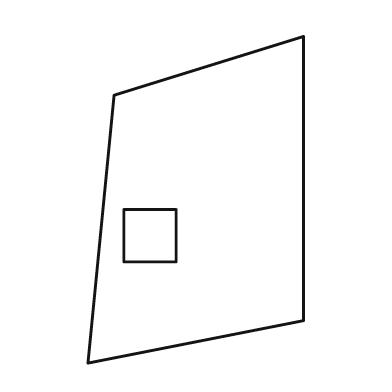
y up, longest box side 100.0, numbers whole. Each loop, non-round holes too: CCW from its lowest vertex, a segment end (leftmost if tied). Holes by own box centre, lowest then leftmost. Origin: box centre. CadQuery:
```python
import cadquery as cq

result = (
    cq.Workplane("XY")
    .moveTo(-33.0, -50.0)
    .lineTo(33.0, -37.0)
    .lineTo(33.0, 50.0)
    .lineTo(-25.0, 32.0)
    .close()
    .moveTo(-22.0, -19.0)
    .lineTo(-6.0, -19.0)
    .lineTo(-6.0, -3.0)
    .lineTo(-22.0, -3.0)
    .close()
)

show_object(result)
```